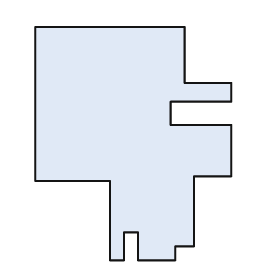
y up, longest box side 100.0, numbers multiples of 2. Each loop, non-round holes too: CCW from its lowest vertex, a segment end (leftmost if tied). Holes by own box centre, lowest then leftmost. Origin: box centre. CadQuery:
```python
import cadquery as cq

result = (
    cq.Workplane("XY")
    .moveTo(-10.0, -50.0)
    .lineTo(-4.0, -50.0)
    .lineTo(-4.0, -38.0)
    .lineTo(2.0, -38.0)
    .lineTo(2.0, -50.0)
    .lineTo(18.0, -50.0)
    .lineTo(18.0, -44.0)
    .lineTo(26.0, -44.0)
    .lineTo(26.0, -14.0)
    .lineTo(42.0, -14.0)
    .lineTo(42.0, 8.0)
    .lineTo(16.0, 8.0)
    .lineTo(16.0, 18.0)
    .lineTo(42.0, 18.0)
    .lineTo(42.0, 26.0)
    .lineTo(22.0, 26.0)
    .lineTo(22.0, 50.0)
    .lineTo(-42.0, 50.0)
    .lineTo(-42.0, -16.0)
    .lineTo(-10.0, -16.0)
    .close()
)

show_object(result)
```